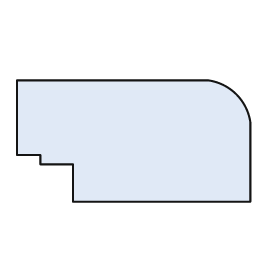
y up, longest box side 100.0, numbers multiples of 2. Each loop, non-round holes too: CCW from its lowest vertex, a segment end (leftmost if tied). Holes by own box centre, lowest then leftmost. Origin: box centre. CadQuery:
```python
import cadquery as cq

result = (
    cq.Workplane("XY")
    .moveTo(-26.0, -26.0)
    .lineTo(50.0, -26.0)
    .lineTo(50.0, 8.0)
    .threePointArc((44.0, 20.0), (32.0, 26.0))
    .lineTo(-50.0, 26.0)
    .lineTo(-50.0, -6.0)
    .lineTo(-40.0, -6.0)
    .lineTo(-40.0, -10.0)
    .lineTo(-26.0, -10.0)
    .close()
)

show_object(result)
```